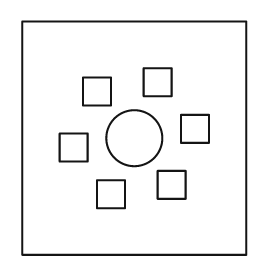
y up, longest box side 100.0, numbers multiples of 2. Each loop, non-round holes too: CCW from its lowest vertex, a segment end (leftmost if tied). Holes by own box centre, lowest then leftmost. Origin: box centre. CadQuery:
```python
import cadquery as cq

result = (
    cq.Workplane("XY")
    .moveTo(-48.0, -50.0)
    .lineTo(48.0, -50.0)
    .lineTo(48.0, 50.0)
    .lineTo(-48.0, 50.0)
    .close()
    .moveTo(-16.0, -30.0)
    .lineTo(-4.0, -30.0)
    .lineTo(-4.0, -18.0)
    .lineTo(-16.0, -18.0)
    .close()
    .moveTo(10.0, -26.0)
    .lineTo(22.0, -26.0)
    .lineTo(22.0, -14.0)
    .lineTo(10.0, -14.0)
    .close()
    .moveTo(-32.0, -10.0)
    .lineTo(-20.0, -10.0)
    .lineTo(-20.0, 2.0)
    .lineTo(-32.0, 2.0)
    .close()
    .moveTo(0.0, 0.0)
    .circle(12.0)
    .moveTo(20.0, -2.0)
    .lineTo(32.0, -2.0)
    .lineTo(32.0, 10.0)
    .lineTo(20.0, 10.0)
    .close()
    .moveTo(-22.0, 14.0)
    .lineTo(-10.0, 14.0)
    .lineTo(-10.0, 26.0)
    .lineTo(-22.0, 26.0)
    .close()
    .moveTo(4.0, 18.0)
    .lineTo(16.0, 18.0)
    .lineTo(16.0, 30.0)
    .lineTo(4.0, 30.0)
    .close()
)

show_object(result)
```